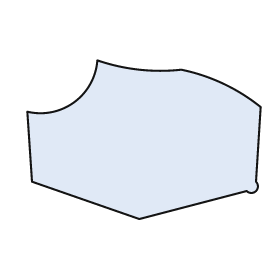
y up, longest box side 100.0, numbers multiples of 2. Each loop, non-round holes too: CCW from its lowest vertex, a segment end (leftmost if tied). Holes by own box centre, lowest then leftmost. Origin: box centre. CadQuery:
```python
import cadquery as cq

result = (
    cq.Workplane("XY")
    .moveTo(-2.0, -34.0)
    .lineTo(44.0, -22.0)
    .threePointArc((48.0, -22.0), (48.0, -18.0))
    .lineTo(50.0, 14.0)
    .threePointArc((34.0, 24.0), (16.0, 30.0))
    .threePointArc((-2.0, 30.0), (-20.0, 34.0))
    .threePointArc((-30.0, 16.0), (-50.0, 12.0))
    .lineTo(-48.0, -18.0)
    .close()
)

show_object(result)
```